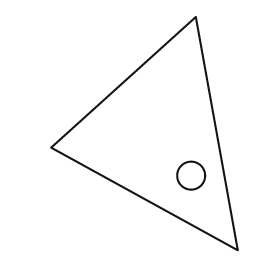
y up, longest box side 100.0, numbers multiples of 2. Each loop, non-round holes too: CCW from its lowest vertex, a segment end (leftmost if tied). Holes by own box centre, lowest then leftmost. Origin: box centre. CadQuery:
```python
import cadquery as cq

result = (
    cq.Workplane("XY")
    .moveTo(40.0, -50.0)
    .lineTo(22.0, 50.0)
    .lineTo(-40.0, -6.0)
    .close()
    .moveTo(20.0, -18.0)
    .circle(6.0)
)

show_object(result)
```